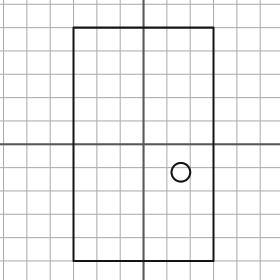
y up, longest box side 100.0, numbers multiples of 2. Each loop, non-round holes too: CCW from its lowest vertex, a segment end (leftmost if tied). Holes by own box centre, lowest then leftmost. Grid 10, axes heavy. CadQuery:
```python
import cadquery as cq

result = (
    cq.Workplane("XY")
    .moveTo(-30.0, -50.0)
    .lineTo(30.0, -50.0)
    .lineTo(30.0, 50.0)
    .lineTo(-30.0, 50.0)
    .close()
    .moveTo(16.0, -12.0)
    .circle(4.0)
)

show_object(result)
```